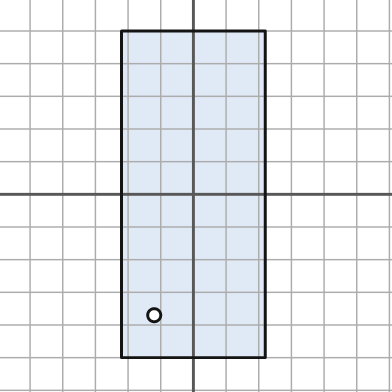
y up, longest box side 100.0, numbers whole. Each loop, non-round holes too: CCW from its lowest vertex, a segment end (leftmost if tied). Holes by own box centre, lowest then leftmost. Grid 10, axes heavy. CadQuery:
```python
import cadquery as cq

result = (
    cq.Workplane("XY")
    .moveTo(-22.0, -50.0)
    .lineTo(22.0, -50.0)
    .lineTo(22.0, 50.0)
    .lineTo(-22.0, 50.0)
    .close()
    .moveTo(-12.0, -37.0)
    .circle(2.0)
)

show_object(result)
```